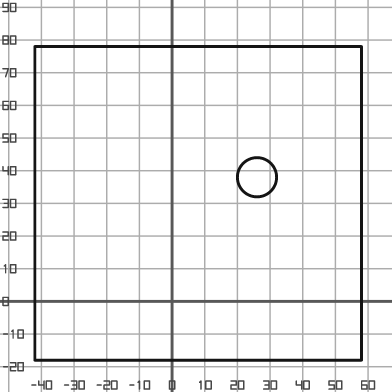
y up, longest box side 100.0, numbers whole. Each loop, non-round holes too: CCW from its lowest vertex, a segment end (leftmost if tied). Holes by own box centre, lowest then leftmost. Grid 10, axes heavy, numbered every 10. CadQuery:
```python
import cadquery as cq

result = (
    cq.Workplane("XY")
    .moveTo(-42.0, -18.0)
    .lineTo(58.0, -18.0)
    .lineTo(58.0, 78.0)
    .lineTo(-42.0, 78.0)
    .close()
    .moveTo(26.0, 38.0)
    .circle(6.0)
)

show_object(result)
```